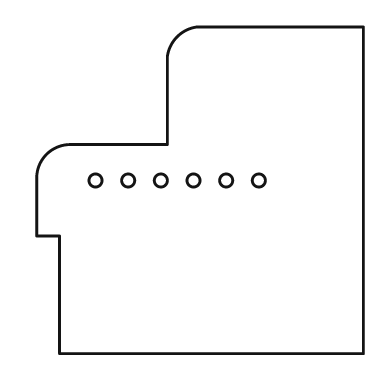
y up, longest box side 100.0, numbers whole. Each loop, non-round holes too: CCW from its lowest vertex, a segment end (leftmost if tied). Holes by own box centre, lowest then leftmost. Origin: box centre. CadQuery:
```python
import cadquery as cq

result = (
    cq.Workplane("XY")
    .moveTo(-43.0, -50.0)
    .lineTo(50.0, -50.0)
    .lineTo(50.0, 50.0)
    .lineTo(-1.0, 50.0)
    .threePointArc((-7.0, 47.0), (-10.0, 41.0))
    .lineTo(-10.0, 14.0)
    .lineTo(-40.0, 14.0)
    .threePointArc((-47.0, 11.0), (-50.0, 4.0))
    .lineTo(-50.0, -14.0)
    .lineTo(-43.0, -14.0)
    .close()
    .moveTo(-32.0, 3.0)
    .circle(2.0)
    .moveTo(-22.0, 3.0)
    .circle(2.0)
    .moveTo(-12.0, 3.0)
    .circle(2.0)
    .moveTo(-2.0, 3.0)
    .circle(2.0)
    .moveTo(8.0, 3.0)
    .circle(2.0)
    .moveTo(18.0, 3.0)
    .circle(2.0)
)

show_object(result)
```